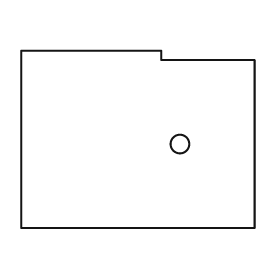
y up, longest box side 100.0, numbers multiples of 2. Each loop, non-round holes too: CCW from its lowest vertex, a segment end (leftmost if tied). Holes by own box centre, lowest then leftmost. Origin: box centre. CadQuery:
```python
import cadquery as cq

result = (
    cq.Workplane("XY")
    .moveTo(-50.0, -38.0)
    .lineTo(50.0, -38.0)
    .lineTo(50.0, 34.0)
    .lineTo(10.0, 34.0)
    .lineTo(10.0, 38.0)
    .lineTo(-50.0, 38.0)
    .close()
    .moveTo(18.0, -2.0)
    .circle(4.0)
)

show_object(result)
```